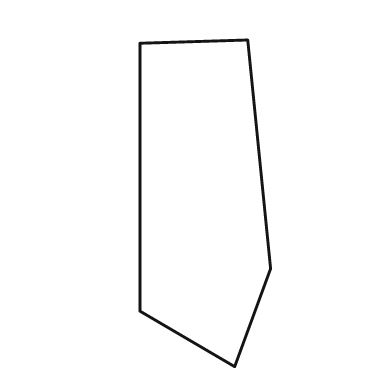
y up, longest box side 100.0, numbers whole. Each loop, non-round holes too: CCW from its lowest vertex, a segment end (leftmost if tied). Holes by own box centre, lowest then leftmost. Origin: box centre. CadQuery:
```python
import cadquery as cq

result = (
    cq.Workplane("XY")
    .moveTo(9.0, -50.0)
    .lineTo(20.0, -20.0)
    .lineTo(13.0, 50.0)
    .lineTo(-20.0, 49.0)
    .lineTo(-20.0, -33.0)
    .close()
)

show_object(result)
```